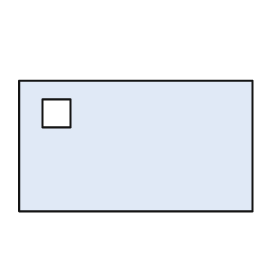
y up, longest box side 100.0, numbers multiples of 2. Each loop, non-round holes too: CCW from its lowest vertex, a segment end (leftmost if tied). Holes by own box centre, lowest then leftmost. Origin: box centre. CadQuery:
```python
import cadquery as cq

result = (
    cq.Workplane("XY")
    .moveTo(-50.0, -28.0)
    .lineTo(50.0, -28.0)
    .lineTo(50.0, 28.0)
    .lineTo(-50.0, 28.0)
    .close()
    .moveTo(-40.0, 8.0)
    .lineTo(-28.0, 8.0)
    .lineTo(-28.0, 20.0)
    .lineTo(-40.0, 20.0)
    .close()
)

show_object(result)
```